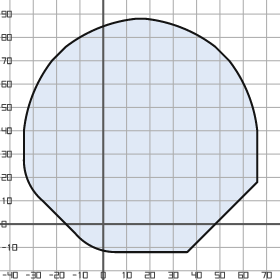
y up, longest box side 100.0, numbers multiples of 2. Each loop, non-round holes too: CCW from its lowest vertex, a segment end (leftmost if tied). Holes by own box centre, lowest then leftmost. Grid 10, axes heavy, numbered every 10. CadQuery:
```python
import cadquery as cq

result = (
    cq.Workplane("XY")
    .moveTo(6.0, -12.0)
    .lineTo(36.0, -12.0)
    .lineTo(66.0, 18.0)
    .lineTo(66.0, 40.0)
    .threePointArc((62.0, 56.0), (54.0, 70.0))
    .lineTo(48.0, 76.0)
    .threePointArc((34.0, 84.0), (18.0, 88.0))
    .lineTo(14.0, 88.0)
    .threePointArc((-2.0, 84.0), (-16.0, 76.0))
    .lineTo(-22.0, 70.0)
    .threePointArc((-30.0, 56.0), (-34.0, 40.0))
    .lineTo(-34.0, 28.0)
    .threePointArc((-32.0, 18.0), (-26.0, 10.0))
    .lineTo(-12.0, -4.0)
    .threePointArc((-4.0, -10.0), (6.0, -12.0))
    .close()
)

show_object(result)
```